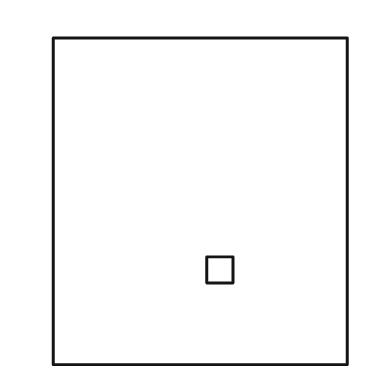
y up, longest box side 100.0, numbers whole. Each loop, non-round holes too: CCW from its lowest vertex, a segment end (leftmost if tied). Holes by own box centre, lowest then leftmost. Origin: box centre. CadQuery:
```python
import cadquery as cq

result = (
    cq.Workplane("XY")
    .moveTo(-45.0, -50.0)
    .lineTo(45.0, -50.0)
    .lineTo(45.0, 50.0)
    .lineTo(-45.0, 50.0)
    .close()
    .moveTo(2.0, -25.0)
    .lineTo(10.0, -25.0)
    .lineTo(10.0, -17.0)
    .lineTo(2.0, -17.0)
    .close()
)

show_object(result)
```